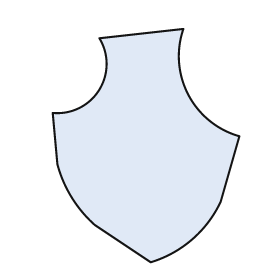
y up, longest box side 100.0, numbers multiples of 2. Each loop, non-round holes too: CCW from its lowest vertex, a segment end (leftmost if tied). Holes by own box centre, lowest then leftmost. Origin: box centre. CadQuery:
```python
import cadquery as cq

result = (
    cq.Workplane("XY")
    .moveTo(2.0, -50.0)
    .threePointArc((20.0, -40.0), (32.0, -24.0))
    .lineTo(40.0, 4.0)
    .threePointArc((18.0, 22.0), (16.0, 50.0))
    .lineTo(-20.0, 46.0)
    .threePointArc((-20.0, 24.0), (-40.0, 14.0))
    .lineTo(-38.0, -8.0)
    .threePointArc((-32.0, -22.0), (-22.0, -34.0))
    .close()
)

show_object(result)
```